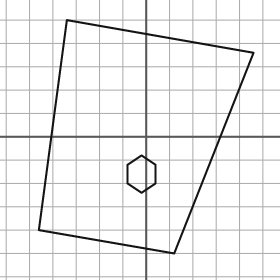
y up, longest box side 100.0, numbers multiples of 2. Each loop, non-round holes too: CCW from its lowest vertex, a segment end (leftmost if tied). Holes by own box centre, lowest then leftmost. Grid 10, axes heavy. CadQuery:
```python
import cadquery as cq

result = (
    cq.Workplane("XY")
    .moveTo(12.0, -50.0)
    .lineTo(46.0, 36.0)
    .lineTo(-34.0, 50.0)
    .lineTo(-46.0, -40.0)
    .close()
    .moveTo(-2.0, -24.0)
    .lineTo(4.0, -20.0)
    .lineTo(4.0, -12.0)
    .lineTo(-2.0, -8.0)
    .lineTo(-8.0, -12.0)
    .lineTo(-8.0, -20.0)
    .close()
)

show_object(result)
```